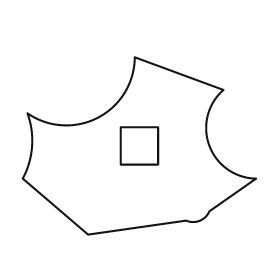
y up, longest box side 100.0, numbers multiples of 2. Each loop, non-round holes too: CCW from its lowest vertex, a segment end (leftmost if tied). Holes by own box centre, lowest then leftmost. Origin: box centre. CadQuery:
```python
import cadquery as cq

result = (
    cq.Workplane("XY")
    .moveTo(-22.0, -38.0)
    .lineTo(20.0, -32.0)
    .threePointArc((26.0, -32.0), (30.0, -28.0))
    .lineTo(50.0, -14.0)
    .threePointArc((30.0, 0.0), (36.0, 24.0))
    .lineTo(-2.0, 38.0)
    .threePointArc((-18.0, 12.0), (-48.0, 14.0))
    .threePointArc((-46.0, 0.0), (-50.0, -14.0))
    .close()
    .moveTo(-8.0, -8.0)
    .lineTo(8.0, -8.0)
    .lineTo(8.0, 8.0)
    .lineTo(-8.0, 8.0)
    .close()
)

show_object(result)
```